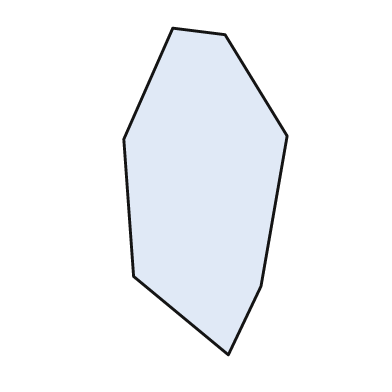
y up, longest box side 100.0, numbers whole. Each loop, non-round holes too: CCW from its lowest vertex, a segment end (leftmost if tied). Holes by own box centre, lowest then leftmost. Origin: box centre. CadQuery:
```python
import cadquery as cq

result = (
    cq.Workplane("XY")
    .moveTo(7.0, -50.0)
    .lineTo(17.0, -29.0)
    .lineTo(25.0, 17.0)
    .lineTo(6.0, 48.0)
    .lineTo(-10.0, 50.0)
    .lineTo(-25.0, 16.0)
    .lineTo(-22.0, -26.0)
    .close()
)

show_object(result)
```